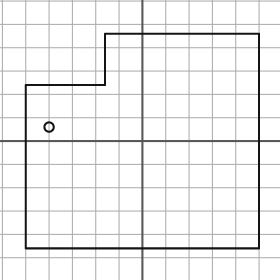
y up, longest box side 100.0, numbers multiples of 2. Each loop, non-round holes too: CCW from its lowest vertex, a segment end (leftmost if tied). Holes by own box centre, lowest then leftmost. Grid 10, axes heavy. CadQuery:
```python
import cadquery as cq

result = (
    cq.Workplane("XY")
    .moveTo(-50.0, -46.0)
    .lineTo(50.0, -46.0)
    .lineTo(50.0, 46.0)
    .lineTo(-16.0, 46.0)
    .lineTo(-16.0, 24.0)
    .lineTo(-50.0, 24.0)
    .close()
    .moveTo(-40.0, 6.0)
    .circle(2.0)
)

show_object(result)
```